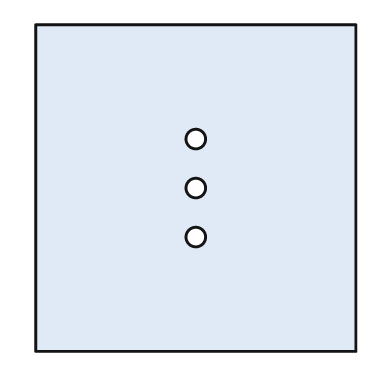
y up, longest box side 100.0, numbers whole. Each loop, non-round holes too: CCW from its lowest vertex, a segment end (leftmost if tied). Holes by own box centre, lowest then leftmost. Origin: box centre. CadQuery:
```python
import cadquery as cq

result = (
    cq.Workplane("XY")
    .moveTo(-49.0, -50.0)
    .lineTo(49.0, -50.0)
    .lineTo(49.0, 50.0)
    .lineTo(-49.0, 50.0)
    .close()
    .moveTo(0.0, -15.0)
    .circle(3.0)
    .moveTo(0.0, 0.0)
    .circle(3.0)
    .moveTo(0.0, 15.0)
    .circle(3.0)
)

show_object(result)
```